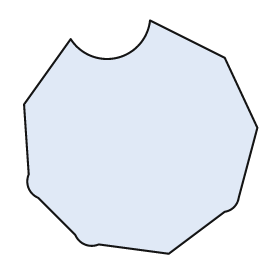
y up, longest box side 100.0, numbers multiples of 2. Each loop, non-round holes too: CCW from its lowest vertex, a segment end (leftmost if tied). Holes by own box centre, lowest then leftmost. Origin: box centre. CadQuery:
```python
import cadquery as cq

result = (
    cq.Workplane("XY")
    .moveTo(12.0, -50.0)
    .lineTo(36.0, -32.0)
    .threePointArc((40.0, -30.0), (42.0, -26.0))
    .lineTo(50.0, 4.0)
    .lineTo(36.0, 34.0)
    .lineTo(4.0, 50.0)
    .threePointArc((-10.0, 34.0), (-30.0, 42.0))
    .lineTo(-50.0, 14.0)
    .lineTo(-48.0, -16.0)
    .threePointArc((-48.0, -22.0), (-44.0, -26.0))
    .lineTo(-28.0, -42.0)
    .threePointArc((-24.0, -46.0), (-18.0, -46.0))
    .close()
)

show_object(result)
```